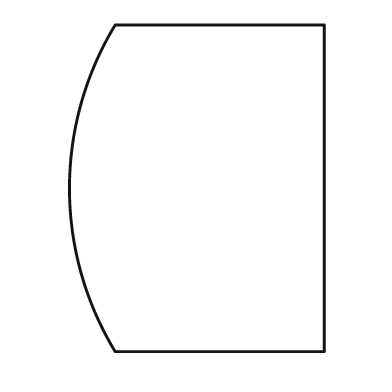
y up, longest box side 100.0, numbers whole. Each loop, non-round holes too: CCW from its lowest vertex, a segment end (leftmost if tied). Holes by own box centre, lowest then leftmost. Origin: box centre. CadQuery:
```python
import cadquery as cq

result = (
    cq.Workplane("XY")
    .moveTo(-25.0, -50.0)
    .lineTo(39.0, -50.0)
    .lineTo(39.0, 50.0)
    .lineTo(-25.0, 50.0)
    .threePointArc((-39.0, 0.0), (-25.0, -50.0))
    .close()
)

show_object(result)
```